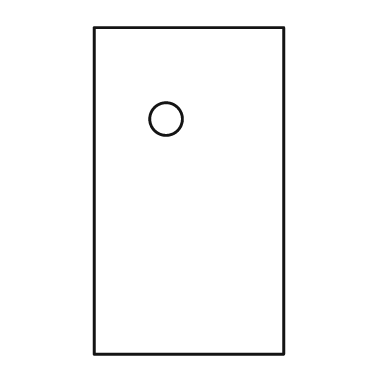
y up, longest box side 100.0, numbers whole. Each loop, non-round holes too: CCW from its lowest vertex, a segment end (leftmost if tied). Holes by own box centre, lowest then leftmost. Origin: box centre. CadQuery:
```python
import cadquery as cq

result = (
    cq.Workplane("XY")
    .moveTo(-29.0, -50.0)
    .lineTo(29.0, -50.0)
    .lineTo(29.0, 50.0)
    .lineTo(-29.0, 50.0)
    .close()
    .moveTo(-7.0, 22.0)
    .circle(5.0)
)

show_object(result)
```